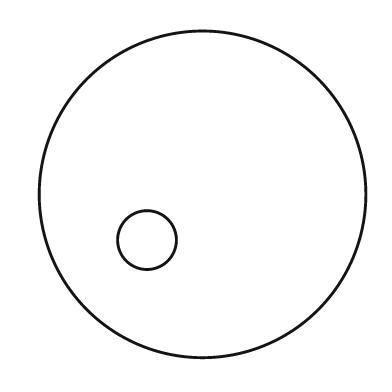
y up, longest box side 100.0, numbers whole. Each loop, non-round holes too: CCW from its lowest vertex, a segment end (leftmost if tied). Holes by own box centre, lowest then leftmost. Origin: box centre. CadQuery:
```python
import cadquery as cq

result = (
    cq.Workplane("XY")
    .moveTo(0.0, 0.0)
    .circle(50.0)
    .moveTo(-17.0, -14.0)
    .circle(9.0)
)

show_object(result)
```